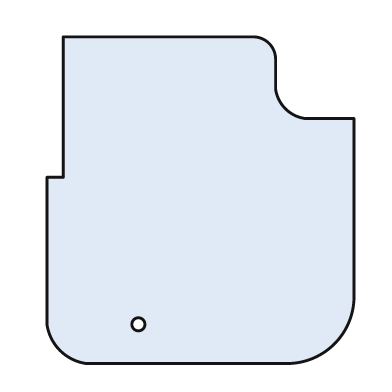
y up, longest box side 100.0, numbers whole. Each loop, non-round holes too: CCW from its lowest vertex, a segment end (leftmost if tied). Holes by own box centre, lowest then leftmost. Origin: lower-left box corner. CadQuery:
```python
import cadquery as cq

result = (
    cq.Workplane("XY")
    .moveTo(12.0, 0.0)
    .lineTo(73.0, 0.0)
    .threePointArc((88.0, 6.0), (94.0, 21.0))
    .lineTo(94.0, 75.0)
    .lineTo(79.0, 75.0)
    .threePointArc((73.0, 78.0), (70.0, 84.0))
    .lineTo(70.0, 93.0)
    .threePointArc((68.0, 98.0), (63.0, 100.0))
    .lineTo(5.0, 100.0)
    .lineTo(5.0, 57.0)
    .lineTo(0.0, 57.0)
    .lineTo(0.0, 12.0)
    .threePointArc((4.0, 4.0), (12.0, 0.0))
    .close()
    .moveTo(28.0, 12.0)
    .circle(2.0)
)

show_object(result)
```